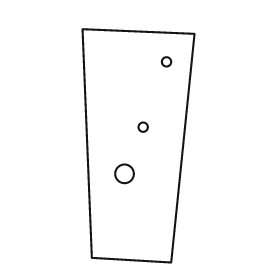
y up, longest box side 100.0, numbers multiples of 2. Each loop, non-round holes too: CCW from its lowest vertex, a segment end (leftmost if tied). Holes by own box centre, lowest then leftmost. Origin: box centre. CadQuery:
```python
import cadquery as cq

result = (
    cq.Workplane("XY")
    .moveTo(14.0, -50.0)
    .lineTo(24.0, 48.0)
    .lineTo(-24.0, 50.0)
    .lineTo(-20.0, -48.0)
    .close()
    .moveTo(-6.0, -12.0)
    .circle(4.0)
    .moveTo(2.0, 8.0)
    .circle(2.0)
    .moveTo(12.0, 36.0)
    .circle(2.0)
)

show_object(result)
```